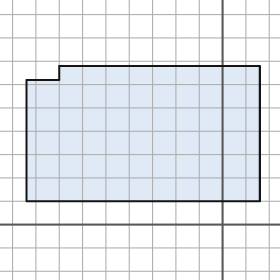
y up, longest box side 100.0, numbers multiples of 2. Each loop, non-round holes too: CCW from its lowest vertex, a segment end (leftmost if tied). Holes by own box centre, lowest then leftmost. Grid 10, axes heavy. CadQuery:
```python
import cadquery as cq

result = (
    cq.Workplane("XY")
    .moveTo(-84.0, 10.0)
    .lineTo(16.0, 10.0)
    .lineTo(16.0, 68.0)
    .lineTo(-70.0, 68.0)
    .lineTo(-70.0, 62.0)
    .lineTo(-84.0, 62.0)
    .close()
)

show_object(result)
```